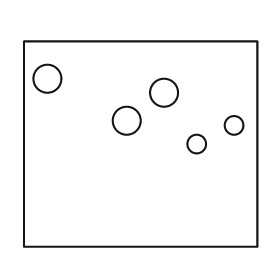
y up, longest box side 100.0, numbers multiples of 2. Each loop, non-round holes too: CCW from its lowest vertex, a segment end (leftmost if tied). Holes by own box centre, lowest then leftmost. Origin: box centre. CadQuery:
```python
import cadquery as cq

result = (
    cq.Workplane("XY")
    .moveTo(-50.0, -44.0)
    .lineTo(50.0, -44.0)
    .lineTo(50.0, 44.0)
    .lineTo(-50.0, 44.0)
    .close()
    .moveTo(24.0, 0.0)
    .circle(4.0)
    .moveTo(40.0, 8.0)
    .circle(4.0)
    .moveTo(-6.0, 10.0)
    .circle(6.0)
    .moveTo(10.0, 22.0)
    .circle(6.0)
    .moveTo(-40.0, 28.0)
    .circle(6.0)
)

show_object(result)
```